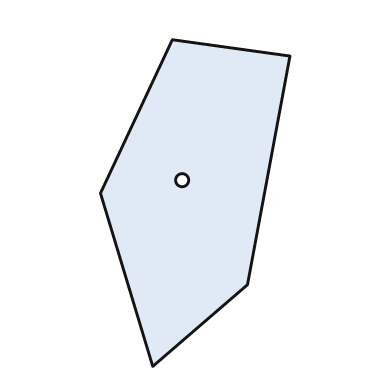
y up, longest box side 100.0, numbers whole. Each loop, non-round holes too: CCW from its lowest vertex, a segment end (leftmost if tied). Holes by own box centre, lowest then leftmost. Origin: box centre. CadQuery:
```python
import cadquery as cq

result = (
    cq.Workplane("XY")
    .moveTo(-13.0, -50.0)
    .lineTo(16.0, -25.0)
    .lineTo(29.0, 45.0)
    .lineTo(-7.0, 50.0)
    .lineTo(-29.0, 3.0)
    .close()
    .moveTo(-4.0, 7.0)
    .circle(2.0)
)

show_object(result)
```